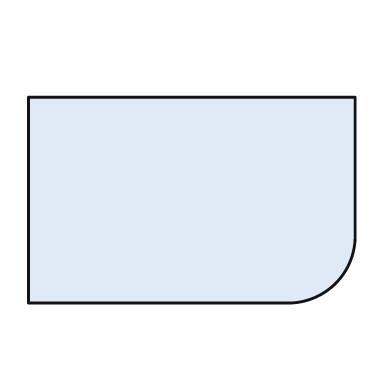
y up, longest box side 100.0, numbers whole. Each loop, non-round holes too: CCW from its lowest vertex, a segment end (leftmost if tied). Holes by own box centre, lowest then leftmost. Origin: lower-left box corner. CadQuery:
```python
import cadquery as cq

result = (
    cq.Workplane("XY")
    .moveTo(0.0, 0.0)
    .lineTo(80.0, 0.0)
    .threePointArc((94.0, 6.0), (100.0, 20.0))
    .lineTo(100.0, 63.0)
    .lineTo(0.0, 63.0)
    .close()
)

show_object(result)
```